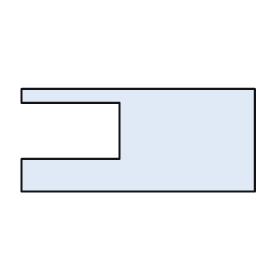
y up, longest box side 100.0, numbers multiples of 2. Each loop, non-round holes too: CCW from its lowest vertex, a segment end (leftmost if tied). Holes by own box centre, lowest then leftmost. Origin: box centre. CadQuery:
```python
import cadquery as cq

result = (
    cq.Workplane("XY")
    .moveTo(-50.0, -22.0)
    .lineTo(50.0, -22.0)
    .lineTo(50.0, 22.0)
    .lineTo(-50.0, 22.0)
    .lineTo(-50.0, 16.0)
    .lineTo(-8.0, 16.0)
    .lineTo(-8.0, -8.0)
    .lineTo(-50.0, -8.0)
    .close()
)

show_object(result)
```